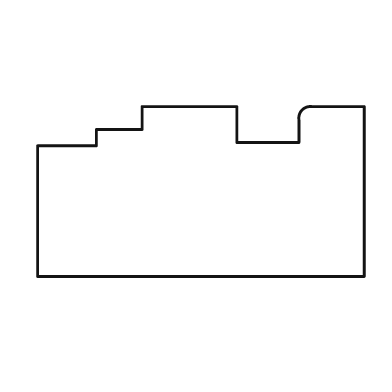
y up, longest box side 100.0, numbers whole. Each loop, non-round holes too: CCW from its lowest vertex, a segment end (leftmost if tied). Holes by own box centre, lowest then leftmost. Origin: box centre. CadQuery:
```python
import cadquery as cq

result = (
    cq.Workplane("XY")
    .moveTo(-50.0, -26.0)
    .lineTo(50.0, -26.0)
    .lineTo(50.0, 26.0)
    .lineTo(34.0, 26.0)
    .threePointArc((31.0, 25.0), (30.0, 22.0))
    .lineTo(30.0, 15.0)
    .lineTo(11.0, 15.0)
    .lineTo(11.0, 26.0)
    .lineTo(-18.0, 26.0)
    .lineTo(-18.0, 19.0)
    .lineTo(-32.0, 19.0)
    .lineTo(-32.0, 14.0)
    .lineTo(-50.0, 14.0)
    .close()
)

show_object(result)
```